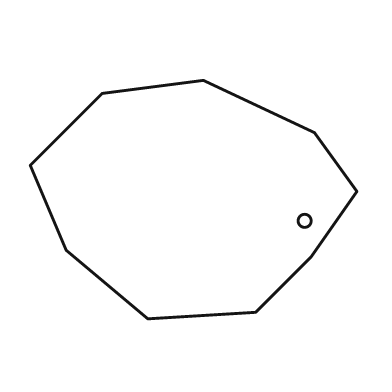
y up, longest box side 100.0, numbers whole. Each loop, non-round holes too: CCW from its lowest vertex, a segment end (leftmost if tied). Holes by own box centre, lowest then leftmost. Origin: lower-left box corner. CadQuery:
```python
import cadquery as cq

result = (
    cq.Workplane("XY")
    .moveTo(36.0, 0.0)
    .lineTo(69.0, 2.0)
    .lineTo(86.0, 19.0)
    .lineTo(100.0, 39.0)
    .lineTo(87.0, 57.0)
    .lineTo(53.0, 73.0)
    .lineTo(22.0, 69.0)
    .lineTo(0.0, 47.0)
    .lineTo(11.0, 21.0)
    .close()
    .moveTo(84.0, 30.0)
    .circle(2.0)
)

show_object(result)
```